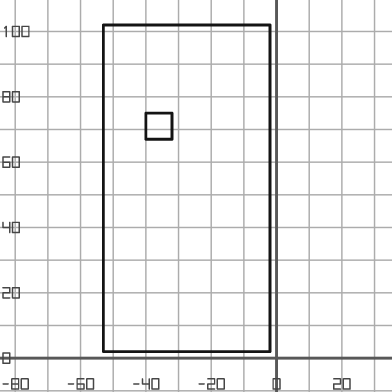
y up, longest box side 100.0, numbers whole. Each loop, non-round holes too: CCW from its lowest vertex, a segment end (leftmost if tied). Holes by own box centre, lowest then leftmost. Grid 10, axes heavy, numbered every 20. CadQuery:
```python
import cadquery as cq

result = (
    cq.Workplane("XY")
    .moveTo(-53.0, 2.0)
    .lineTo(-2.0, 2.0)
    .lineTo(-2.0, 102.0)
    .lineTo(-53.0, 102.0)
    .close()
    .moveTo(-40.0, 67.0)
    .lineTo(-32.0, 67.0)
    .lineTo(-32.0, 75.0)
    .lineTo(-40.0, 75.0)
    .close()
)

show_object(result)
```